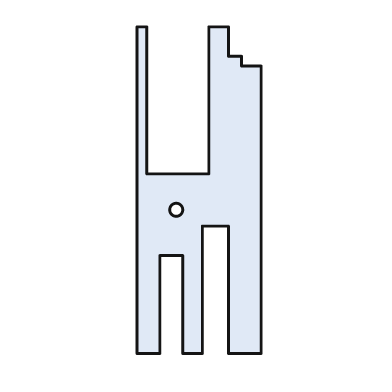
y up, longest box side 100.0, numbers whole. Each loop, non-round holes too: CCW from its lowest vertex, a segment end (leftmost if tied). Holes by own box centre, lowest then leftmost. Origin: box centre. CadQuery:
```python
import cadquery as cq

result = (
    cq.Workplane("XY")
    .moveTo(-19.0, -50.0)
    .lineTo(-12.0, -50.0)
    .lineTo(-12.0, -20.0)
    .lineTo(-5.0, -20.0)
    .lineTo(-5.0, -50.0)
    .lineTo(1.0, -50.0)
    .lineTo(1.0, -11.0)
    .lineTo(9.0, -11.0)
    .lineTo(9.0, -50.0)
    .lineTo(19.0, -50.0)
    .lineTo(19.0, 38.0)
    .lineTo(13.0, 38.0)
    .lineTo(13.0, 41.0)
    .lineTo(9.0, 41.0)
    .lineTo(9.0, 50.0)
    .lineTo(3.0, 50.0)
    .lineTo(3.0, 5.0)
    .lineTo(-16.0, 5.0)
    .lineTo(-16.0, 50.0)
    .lineTo(-19.0, 50.0)
    .close()
    .moveTo(-7.0, -6.0)
    .circle(2.0)
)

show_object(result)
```